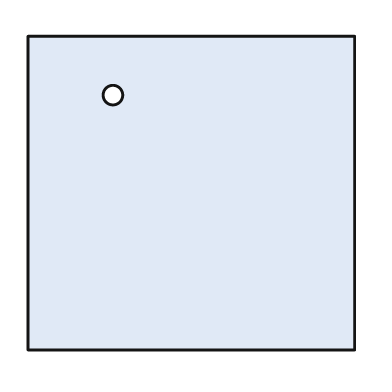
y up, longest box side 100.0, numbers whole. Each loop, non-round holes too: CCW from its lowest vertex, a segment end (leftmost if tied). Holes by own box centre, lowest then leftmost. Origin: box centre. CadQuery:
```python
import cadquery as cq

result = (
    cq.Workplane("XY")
    .moveTo(-50.0, -48.0)
    .lineTo(50.0, -48.0)
    .lineTo(50.0, 48.0)
    .lineTo(-50.0, 48.0)
    .close()
    .moveTo(-24.0, 30.0)
    .circle(3.0)
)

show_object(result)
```